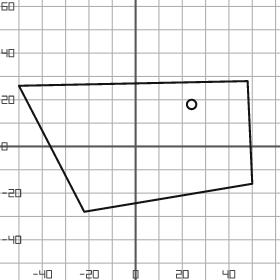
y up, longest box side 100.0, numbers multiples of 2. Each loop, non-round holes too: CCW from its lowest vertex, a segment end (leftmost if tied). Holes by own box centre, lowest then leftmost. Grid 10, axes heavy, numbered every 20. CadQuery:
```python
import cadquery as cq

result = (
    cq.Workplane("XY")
    .moveTo(-22.0, -28.0)
    .lineTo(50.0, -16.0)
    .lineTo(48.0, 28.0)
    .lineTo(-50.0, 26.0)
    .close()
    .moveTo(24.0, 18.0)
    .circle(2.0)
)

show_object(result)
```